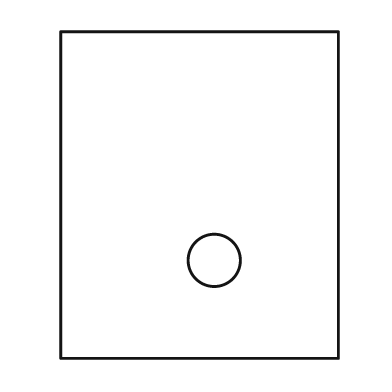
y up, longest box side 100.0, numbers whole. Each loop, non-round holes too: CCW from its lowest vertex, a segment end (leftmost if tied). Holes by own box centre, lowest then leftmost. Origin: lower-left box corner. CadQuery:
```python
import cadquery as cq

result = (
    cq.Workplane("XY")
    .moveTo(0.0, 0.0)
    .lineTo(85.0, 0.0)
    .lineTo(85.0, 100.0)
    .lineTo(0.0, 100.0)
    .close()
    .moveTo(47.0, 30.0)
    .circle(8.0)
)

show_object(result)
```